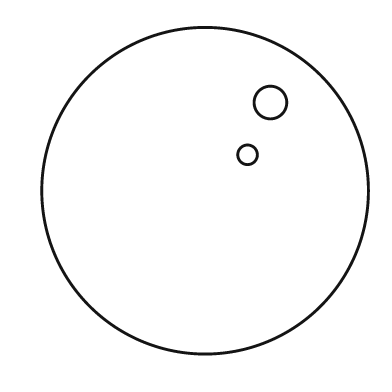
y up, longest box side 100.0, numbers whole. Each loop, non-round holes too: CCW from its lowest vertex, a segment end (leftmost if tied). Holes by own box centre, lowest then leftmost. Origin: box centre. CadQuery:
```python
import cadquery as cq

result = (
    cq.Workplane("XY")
    .moveTo(0.0, 0.0)
    .circle(50.0)
    .moveTo(13.0, 11.0)
    .circle(3.0)
    .moveTo(20.0, 27.0)
    .circle(5.0)
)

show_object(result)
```